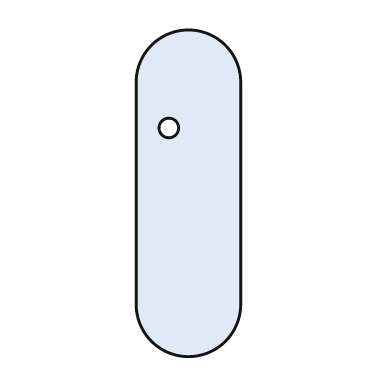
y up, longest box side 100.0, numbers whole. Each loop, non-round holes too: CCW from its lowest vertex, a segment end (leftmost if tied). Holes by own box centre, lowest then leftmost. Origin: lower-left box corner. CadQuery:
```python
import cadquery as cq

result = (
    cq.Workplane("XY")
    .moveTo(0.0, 16.0)
    .threePointArc((16.0, 0.0), (32.0, 16.0))
    .lineTo(32.0, 84.0)
    .threePointArc((16.0, 100.0), (0.0, 84.0))
    .close()
    .moveTo(10.0, 70.0)
    .circle(3.0)
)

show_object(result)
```